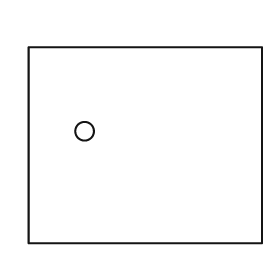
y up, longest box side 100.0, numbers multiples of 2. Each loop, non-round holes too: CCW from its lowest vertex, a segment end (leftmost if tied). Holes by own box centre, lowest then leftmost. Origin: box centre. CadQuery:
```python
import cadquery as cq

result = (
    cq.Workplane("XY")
    .moveTo(-50.0, -42.0)
    .lineTo(50.0, -42.0)
    .lineTo(50.0, 42.0)
    .lineTo(-50.0, 42.0)
    .close()
    .moveTo(-26.0, 6.0)
    .circle(4.0)
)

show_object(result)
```